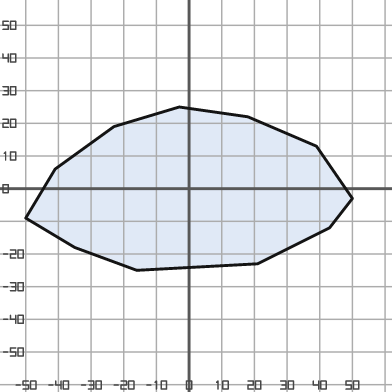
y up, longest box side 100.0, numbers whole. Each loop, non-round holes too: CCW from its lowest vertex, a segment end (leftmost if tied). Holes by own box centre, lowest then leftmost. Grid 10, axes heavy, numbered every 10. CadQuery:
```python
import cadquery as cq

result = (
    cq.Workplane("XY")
    .moveTo(-16.0, -25.0)
    .lineTo(21.0, -23.0)
    .lineTo(43.0, -12.0)
    .lineTo(50.0, -3.0)
    .lineTo(39.0, 13.0)
    .lineTo(18.0, 22.0)
    .lineTo(-3.0, 25.0)
    .lineTo(-23.0, 19.0)
    .lineTo(-41.0, 6.0)
    .lineTo(-50.0, -9.0)
    .lineTo(-35.0, -18.0)
    .close()
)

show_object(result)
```